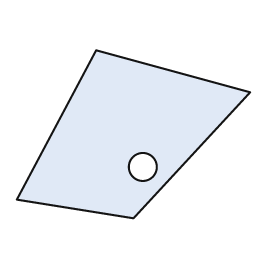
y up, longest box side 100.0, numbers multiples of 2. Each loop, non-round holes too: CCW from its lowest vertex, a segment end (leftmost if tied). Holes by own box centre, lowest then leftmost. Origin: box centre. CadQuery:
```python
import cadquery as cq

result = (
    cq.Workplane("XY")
    .moveTo(0.0, -36.0)
    .lineTo(50.0, 18.0)
    .lineTo(-16.0, 36.0)
    .lineTo(-50.0, -28.0)
    .close()
    .moveTo(4.0, -14.0)
    .circle(6.0)
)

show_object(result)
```